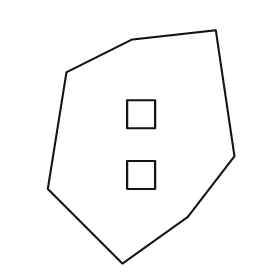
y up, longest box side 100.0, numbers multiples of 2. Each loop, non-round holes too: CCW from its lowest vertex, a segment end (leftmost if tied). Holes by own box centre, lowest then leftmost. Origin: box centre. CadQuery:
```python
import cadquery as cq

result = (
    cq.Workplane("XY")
    .moveTo(-8.0, -50.0)
    .lineTo(20.0, -30.0)
    .lineTo(40.0, -4.0)
    .lineTo(32.0, 50.0)
    .lineTo(-4.0, 46.0)
    .lineTo(-32.0, 32.0)
    .lineTo(-40.0, -18.0)
    .close()
    .moveTo(-6.0, -18.0)
    .lineTo(6.0, -18.0)
    .lineTo(6.0, -6.0)
    .lineTo(-6.0, -6.0)
    .close()
    .moveTo(-6.0, 8.0)
    .lineTo(6.0, 8.0)
    .lineTo(6.0, 20.0)
    .lineTo(-6.0, 20.0)
    .close()
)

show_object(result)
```